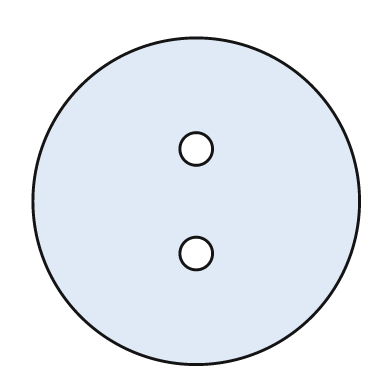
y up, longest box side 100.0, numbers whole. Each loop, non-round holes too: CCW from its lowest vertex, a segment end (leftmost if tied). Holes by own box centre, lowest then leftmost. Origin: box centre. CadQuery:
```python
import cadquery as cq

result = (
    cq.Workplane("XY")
    .moveTo(0.0, 0.0)
    .circle(50.0)
    .moveTo(0.0, -16.0)
    .circle(5.0)
    .moveTo(0.0, 16.0)
    .circle(5.0)
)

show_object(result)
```